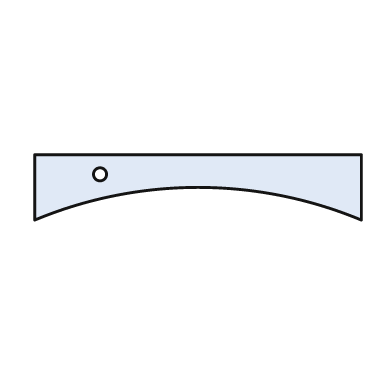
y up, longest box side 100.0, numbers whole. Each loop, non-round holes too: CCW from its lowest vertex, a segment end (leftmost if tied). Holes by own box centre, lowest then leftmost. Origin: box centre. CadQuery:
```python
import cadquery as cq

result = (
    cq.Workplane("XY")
    .moveTo(-50.0, -10.0)
    .threePointArc((0.0, 0.0), (50.0, -10.0))
    .lineTo(50.0, 10.0)
    .lineTo(-50.0, 10.0)
    .close()
    .moveTo(-30.0, 4.0)
    .circle(2.0)
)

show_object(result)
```